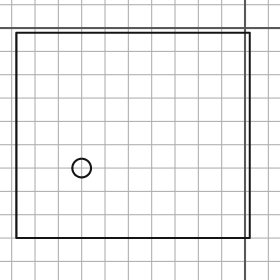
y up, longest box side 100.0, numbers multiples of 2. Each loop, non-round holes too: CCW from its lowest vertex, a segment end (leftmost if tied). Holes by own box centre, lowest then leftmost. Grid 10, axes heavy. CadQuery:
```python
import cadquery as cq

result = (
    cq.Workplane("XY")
    .moveTo(-98.0, -90.0)
    .lineTo(2.0, -90.0)
    .lineTo(2.0, -2.0)
    .lineTo(-98.0, -2.0)
    .close()
    .moveTo(-70.0, -60.0)
    .circle(4.0)
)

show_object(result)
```